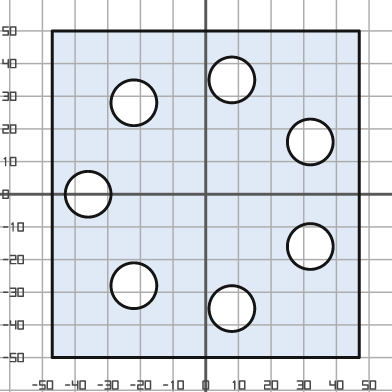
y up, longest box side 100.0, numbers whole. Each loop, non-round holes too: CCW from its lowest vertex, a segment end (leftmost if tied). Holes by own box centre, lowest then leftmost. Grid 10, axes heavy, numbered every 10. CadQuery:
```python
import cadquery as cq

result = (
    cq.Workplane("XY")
    .moveTo(-47.0, -50.0)
    .lineTo(47.0, -50.0)
    .lineTo(47.0, 50.0)
    .lineTo(-47.0, 50.0)
    .close()
    .moveTo(8.0, -35.0)
    .circle(7.0)
    .moveTo(-22.0, -28.0)
    .circle(7.0)
    .moveTo(32.0, -16.0)
    .circle(7.0)
    .moveTo(-36.0, 0.0)
    .circle(7.0)
    .moveTo(32.0, 16.0)
    .circle(7.0)
    .moveTo(-22.0, 28.0)
    .circle(7.0)
    .moveTo(8.0, 35.0)
    .circle(7.0)
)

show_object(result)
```